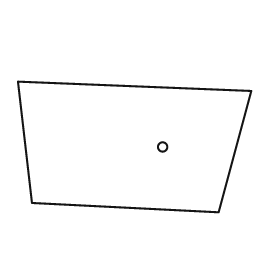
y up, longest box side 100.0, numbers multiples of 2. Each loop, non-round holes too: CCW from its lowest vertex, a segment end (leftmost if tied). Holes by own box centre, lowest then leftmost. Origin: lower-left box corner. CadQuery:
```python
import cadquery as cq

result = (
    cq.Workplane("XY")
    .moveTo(86.0, 0.0)
    .lineTo(100.0, 52.0)
    .lineTo(0.0, 56.0)
    .lineTo(6.0, 4.0)
    .close()
    .moveTo(62.0, 28.0)
    .circle(2.0)
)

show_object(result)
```